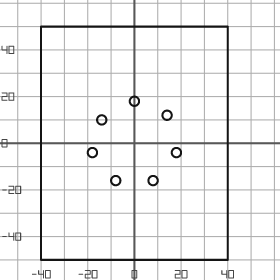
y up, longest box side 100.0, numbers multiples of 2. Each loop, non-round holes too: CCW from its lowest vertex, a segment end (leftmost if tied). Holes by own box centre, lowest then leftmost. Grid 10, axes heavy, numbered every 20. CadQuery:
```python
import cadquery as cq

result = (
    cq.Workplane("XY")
    .moveTo(-40.0, -50.0)
    .lineTo(40.0, -50.0)
    .lineTo(40.0, 50.0)
    .lineTo(-40.0, 50.0)
    .close()
    .moveTo(-8.0, -16.0)
    .circle(2.0)
    .moveTo(8.0, -16.0)
    .circle(2.0)
    .moveTo(-18.0, -4.0)
    .circle(2.0)
    .moveTo(18.0, -4.0)
    .circle(2.0)
    .moveTo(-14.0, 10.0)
    .circle(2.0)
    .moveTo(14.0, 12.0)
    .circle(2.0)
    .moveTo(0.0, 18.0)
    .circle(2.0)
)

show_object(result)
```